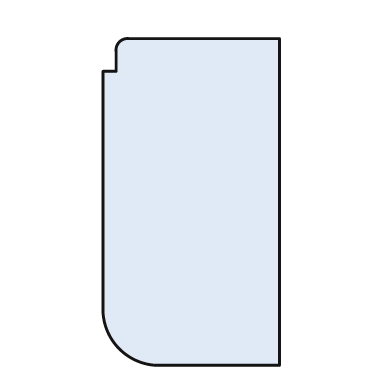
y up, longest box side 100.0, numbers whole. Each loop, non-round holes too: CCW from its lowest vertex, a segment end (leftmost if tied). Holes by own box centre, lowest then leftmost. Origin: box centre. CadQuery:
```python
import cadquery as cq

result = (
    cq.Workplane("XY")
    .moveTo(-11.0, -50.0)
    .lineTo(27.0, -50.0)
    .lineTo(27.0, 50.0)
    .lineTo(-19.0, 50.0)
    .threePointArc((-22.0, 49.0), (-23.0, 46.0))
    .lineTo(-23.0, 40.0)
    .lineTo(-27.0, 40.0)
    .lineTo(-27.0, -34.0)
    .threePointArc((-22.0, -45.0), (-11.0, -50.0))
    .close()
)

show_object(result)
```